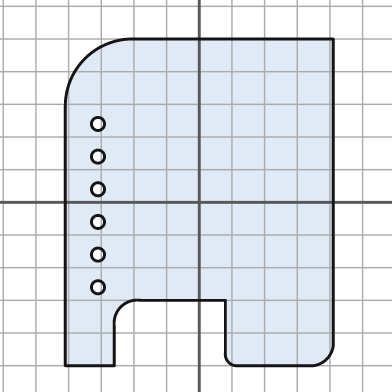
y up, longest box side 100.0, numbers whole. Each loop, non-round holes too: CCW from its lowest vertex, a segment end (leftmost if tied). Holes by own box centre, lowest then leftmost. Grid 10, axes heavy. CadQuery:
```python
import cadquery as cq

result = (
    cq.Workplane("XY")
    .moveTo(-41.0, -50.0)
    .lineTo(-26.0, -50.0)
    .lineTo(-26.0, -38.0)
    .threePointArc((-24.0, -32.0), (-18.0, -30.0))
    .lineTo(8.0, -30.0)
    .lineTo(8.0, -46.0)
    .threePointArc((9.0, -49.0), (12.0, -50.0))
    .lineTo(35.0, -50.0)
    .threePointArc((39.0, -48.0), (41.0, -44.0))
    .lineTo(41.0, 50.0)
    .lineTo(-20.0, 50.0)
    .threePointArc((-35.0, 44.0), (-41.0, 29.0))
    .close()
    .moveTo(-31.0, -26.0)
    .circle(2.0)
    .moveTo(-31.0, -16.0)
    .circle(2.0)
    .moveTo(-31.0, -6.0)
    .circle(2.0)
    .moveTo(-31.0, 4.0)
    .circle(2.0)
    .moveTo(-31.0, 14.0)
    .circle(2.0)
    .moveTo(-31.0, 24.0)
    .circle(2.0)
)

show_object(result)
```